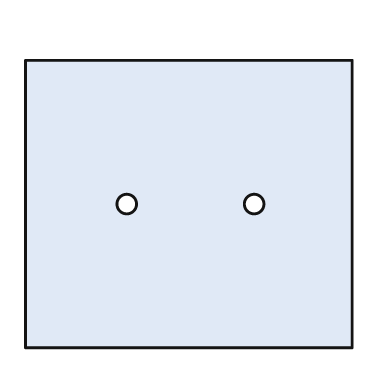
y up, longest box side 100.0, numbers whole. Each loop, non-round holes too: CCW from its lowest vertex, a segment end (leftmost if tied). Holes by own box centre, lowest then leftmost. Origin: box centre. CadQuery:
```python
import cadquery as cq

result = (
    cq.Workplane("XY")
    .moveTo(-50.0, -44.0)
    .lineTo(50.0, -44.0)
    .lineTo(50.0, 44.0)
    .lineTo(-50.0, 44.0)
    .close()
    .moveTo(-19.0, 0.0)
    .circle(3.0)
    .moveTo(20.0, 0.0)
    .circle(3.0)
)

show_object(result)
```